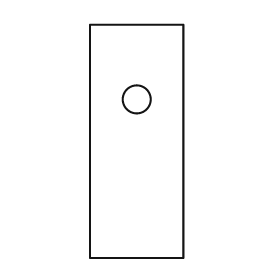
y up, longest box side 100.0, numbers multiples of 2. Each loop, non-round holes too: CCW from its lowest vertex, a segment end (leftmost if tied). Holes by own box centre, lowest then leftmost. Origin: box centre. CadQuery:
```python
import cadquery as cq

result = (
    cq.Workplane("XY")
    .moveTo(-20.0, -50.0)
    .lineTo(20.0, -50.0)
    .lineTo(20.0, 50.0)
    .lineTo(-20.0, 50.0)
    .close()
    .moveTo(0.0, 18.0)
    .circle(6.0)
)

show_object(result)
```